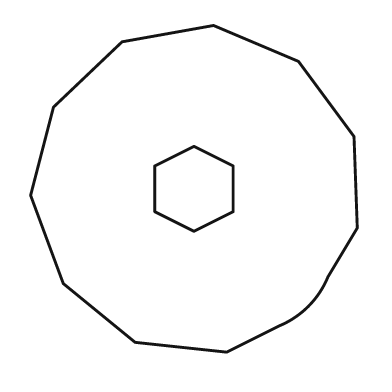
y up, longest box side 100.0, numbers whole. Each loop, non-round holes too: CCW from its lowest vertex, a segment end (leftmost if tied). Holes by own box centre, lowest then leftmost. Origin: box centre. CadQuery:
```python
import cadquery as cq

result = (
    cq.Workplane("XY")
    .moveTo(10.0, -50.0)
    .lineTo(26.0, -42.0)
    .threePointArc((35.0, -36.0), (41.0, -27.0))
    .lineTo(50.0, -12.0)
    .lineTo(49.0, 16.0)
    .lineTo(32.0, 39.0)
    .lineTo(6.0, 50.0)
    .lineTo(-22.0, 45.0)
    .lineTo(-43.0, 25.0)
    .lineTo(-50.0, -2.0)
    .lineTo(-40.0, -29.0)
    .lineTo(-18.0, -47.0)
    .close()
    .moveTo(0.0, -13.0)
    .lineTo(12.0, -7.0)
    .lineTo(12.0, 7.0)
    .lineTo(0.0, 13.0)
    .lineTo(-12.0, 7.0)
    .lineTo(-12.0, -7.0)
    .close()
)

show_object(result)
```